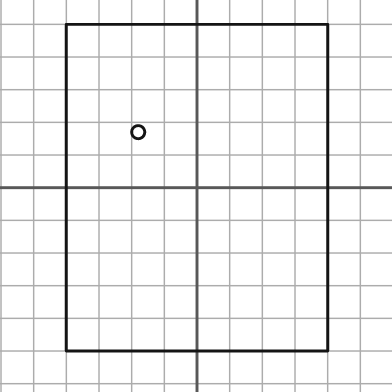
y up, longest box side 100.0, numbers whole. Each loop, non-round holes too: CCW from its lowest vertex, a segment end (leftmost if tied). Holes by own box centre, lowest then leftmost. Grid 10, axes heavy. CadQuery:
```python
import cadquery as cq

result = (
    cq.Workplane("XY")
    .moveTo(-40.0, -50.0)
    .lineTo(40.0, -50.0)
    .lineTo(40.0, 50.0)
    .lineTo(-40.0, 50.0)
    .close()
    .moveTo(-18.0, 17.0)
    .circle(2.0)
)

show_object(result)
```